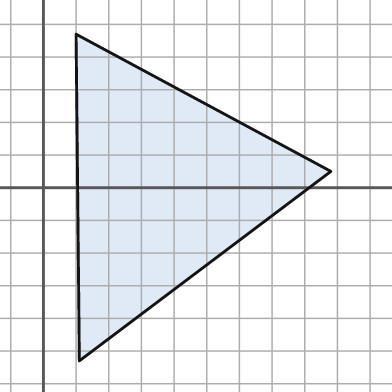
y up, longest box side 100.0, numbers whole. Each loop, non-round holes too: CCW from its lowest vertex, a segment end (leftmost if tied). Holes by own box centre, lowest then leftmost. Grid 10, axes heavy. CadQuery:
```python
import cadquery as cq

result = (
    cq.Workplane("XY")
    .moveTo(11.0, -53.0)
    .lineTo(88.0, 5.0)
    .lineTo(10.0, 47.0)
    .close()
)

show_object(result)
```